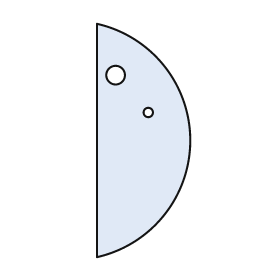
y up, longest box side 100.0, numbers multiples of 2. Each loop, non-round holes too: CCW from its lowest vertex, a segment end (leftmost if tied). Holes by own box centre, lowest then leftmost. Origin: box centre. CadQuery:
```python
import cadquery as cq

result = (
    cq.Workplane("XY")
    .moveTo(-20.0, -50.0)
    .threePointArc((20.0, 0.0), (-20.0, 50.0))
    .close()
    .moveTo(2.0, 12.0)
    .circle(2.0)
    .moveTo(-12.0, 28.0)
    .circle(4.0)
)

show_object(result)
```